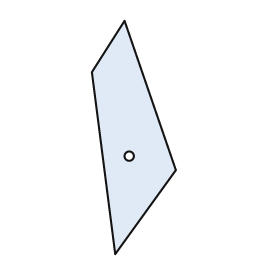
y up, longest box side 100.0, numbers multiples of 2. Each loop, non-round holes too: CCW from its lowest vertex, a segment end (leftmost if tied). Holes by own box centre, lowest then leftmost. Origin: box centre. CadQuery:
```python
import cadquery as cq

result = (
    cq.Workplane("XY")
    .moveTo(-8.0, -50.0)
    .lineTo(18.0, -14.0)
    .lineTo(-4.0, 50.0)
    .lineTo(-18.0, 28.0)
    .close()
    .moveTo(-2.0, -8.0)
    .circle(2.0)
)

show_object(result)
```